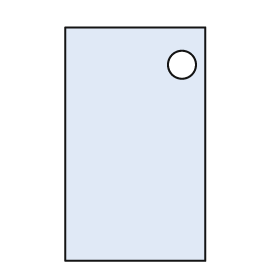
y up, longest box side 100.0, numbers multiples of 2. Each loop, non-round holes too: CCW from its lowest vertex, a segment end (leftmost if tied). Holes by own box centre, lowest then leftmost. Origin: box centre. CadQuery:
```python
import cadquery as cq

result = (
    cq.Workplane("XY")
    .moveTo(-30.0, -50.0)
    .lineTo(30.0, -50.0)
    .lineTo(30.0, 50.0)
    .lineTo(-30.0, 50.0)
    .close()
    .moveTo(20.0, 34.0)
    .circle(6.0)
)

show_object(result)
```